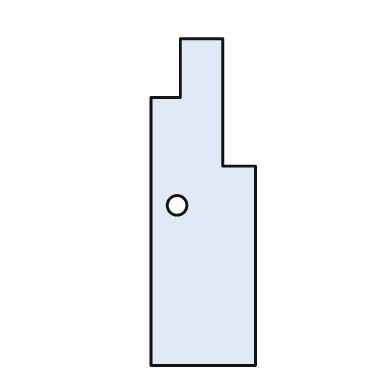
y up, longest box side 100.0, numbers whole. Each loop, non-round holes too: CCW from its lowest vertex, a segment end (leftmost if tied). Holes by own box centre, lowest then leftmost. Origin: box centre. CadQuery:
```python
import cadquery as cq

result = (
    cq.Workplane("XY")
    .moveTo(-16.0, -50.0)
    .lineTo(16.0, -50.0)
    .lineTo(16.0, 11.0)
    .lineTo(6.0, 11.0)
    .lineTo(6.0, 50.0)
    .lineTo(-7.0, 50.0)
    .lineTo(-7.0, 32.0)
    .lineTo(-16.0, 32.0)
    .close()
    .moveTo(-8.0, -1.0)
    .circle(3.0)
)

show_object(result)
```